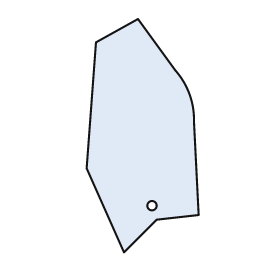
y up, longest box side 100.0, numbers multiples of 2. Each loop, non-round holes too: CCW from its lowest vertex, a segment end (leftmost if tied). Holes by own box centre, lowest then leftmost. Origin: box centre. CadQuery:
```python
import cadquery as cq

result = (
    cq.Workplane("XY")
    .moveTo(-8.0, -50.0)
    .lineTo(6.0, -36.0)
    .lineTo(24.0, -34.0)
    .lineTo(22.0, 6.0)
    .threePointArc((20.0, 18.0), (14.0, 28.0))
    .lineTo(-2.0, 50.0)
    .lineTo(-20.0, 40.0)
    .lineTo(-24.0, -14.0)
    .close()
    .moveTo(4.0, -30.0)
    .circle(2.0)
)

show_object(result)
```